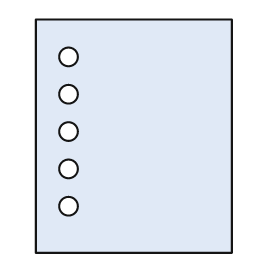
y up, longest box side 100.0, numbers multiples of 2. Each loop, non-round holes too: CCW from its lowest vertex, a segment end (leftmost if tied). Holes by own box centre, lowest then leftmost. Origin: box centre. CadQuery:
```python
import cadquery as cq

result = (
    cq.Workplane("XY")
    .moveTo(-42.0, -50.0)
    .lineTo(42.0, -50.0)
    .lineTo(42.0, 50.0)
    .lineTo(-42.0, 50.0)
    .close()
    .moveTo(-28.0, -30.0)
    .circle(4.0)
    .moveTo(-28.0, -14.0)
    .circle(4.0)
    .moveTo(-28.0, 2.0)
    .circle(4.0)
    .moveTo(-28.0, 18.0)
    .circle(4.0)
    .moveTo(-28.0, 34.0)
    .circle(4.0)
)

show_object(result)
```